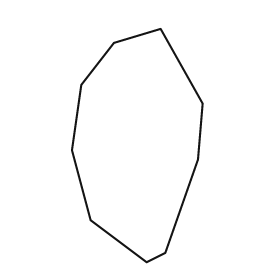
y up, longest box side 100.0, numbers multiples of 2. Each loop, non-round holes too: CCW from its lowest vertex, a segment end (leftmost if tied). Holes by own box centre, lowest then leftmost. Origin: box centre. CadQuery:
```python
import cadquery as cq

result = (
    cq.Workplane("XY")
    .moveTo(4.0, -50.0)
    .lineTo(12.0, -46.0)
    .lineTo(26.0, -6.0)
    .lineTo(28.0, 18.0)
    .lineTo(10.0, 50.0)
    .lineTo(-10.0, 44.0)
    .lineTo(-24.0, 26.0)
    .lineTo(-28.0, -2.0)
    .lineTo(-20.0, -32.0)
    .close()
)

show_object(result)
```